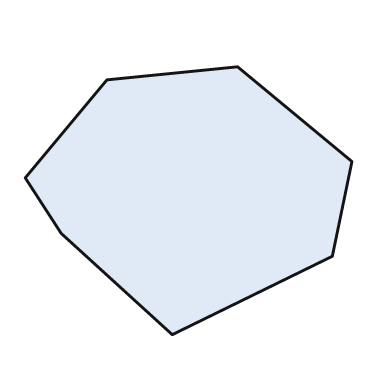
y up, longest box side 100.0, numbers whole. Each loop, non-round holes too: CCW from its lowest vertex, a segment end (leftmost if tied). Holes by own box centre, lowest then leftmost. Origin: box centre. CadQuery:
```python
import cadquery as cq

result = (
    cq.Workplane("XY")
    .moveTo(-5.0, -41.0)
    .lineTo(44.0, -17.0)
    .lineTo(50.0, 12.0)
    .lineTo(15.0, 41.0)
    .lineTo(-25.0, 37.0)
    .lineTo(-50.0, 7.0)
    .lineTo(-39.0, -10.0)
    .close()
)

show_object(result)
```